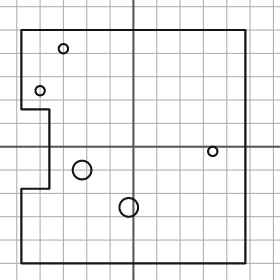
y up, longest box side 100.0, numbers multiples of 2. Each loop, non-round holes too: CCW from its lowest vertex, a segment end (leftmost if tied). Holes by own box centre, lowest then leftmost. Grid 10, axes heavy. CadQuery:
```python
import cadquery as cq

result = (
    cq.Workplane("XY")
    .moveTo(-48.0, -50.0)
    .lineTo(48.0, -50.0)
    .lineTo(48.0, 50.0)
    .lineTo(-48.0, 50.0)
    .lineTo(-48.0, 16.0)
    .lineTo(-36.0, 16.0)
    .lineTo(-36.0, -18.0)
    .lineTo(-48.0, -18.0)
    .close()
    .moveTo(-2.0, -26.0)
    .circle(4.0)
    .moveTo(-22.0, -10.0)
    .circle(4.0)
    .moveTo(34.0, -2.0)
    .circle(2.0)
    .moveTo(-40.0, 24.0)
    .circle(2.0)
    .moveTo(-30.0, 42.0)
    .circle(2.0)
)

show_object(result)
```